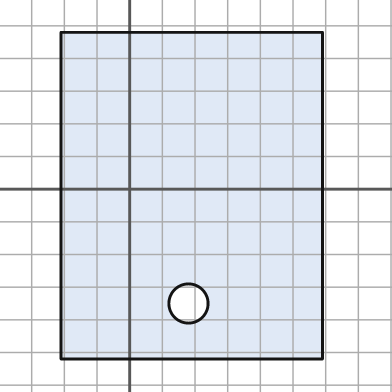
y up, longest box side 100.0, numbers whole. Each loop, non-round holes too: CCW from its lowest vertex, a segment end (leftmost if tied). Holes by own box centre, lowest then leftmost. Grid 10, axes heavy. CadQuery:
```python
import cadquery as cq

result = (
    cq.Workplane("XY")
    .moveTo(-21.0, -52.0)
    .lineTo(59.0, -52.0)
    .lineTo(59.0, 48.0)
    .lineTo(-21.0, 48.0)
    .close()
    .moveTo(18.0, -35.0)
    .circle(6.0)
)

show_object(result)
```